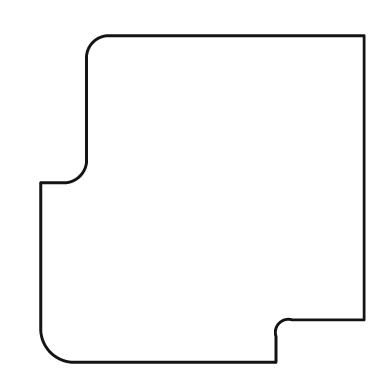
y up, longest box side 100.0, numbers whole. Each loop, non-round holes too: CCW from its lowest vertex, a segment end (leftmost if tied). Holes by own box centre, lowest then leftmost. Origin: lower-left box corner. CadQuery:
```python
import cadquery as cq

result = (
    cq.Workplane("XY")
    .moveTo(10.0, 0.0)
    .lineTo(72.0, 0.0)
    .lineTo(72.0, 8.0)
    .threePointArc((73.0, 12.0), (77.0, 13.0))
    .lineTo(99.0, 13.0)
    .lineTo(99.0, 100.0)
    .lineTo(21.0, 100.0)
    .threePointArc((16.0, 98.0), (14.0, 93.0))
    .lineTo(14.0, 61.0)
    .threePointArc((12.0, 57.0), (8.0, 55.0))
    .lineTo(0.0, 55.0)
    .lineTo(0.0, 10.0)
    .threePointArc((3.0, 3.0), (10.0, 0.0))
    .close()
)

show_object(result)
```